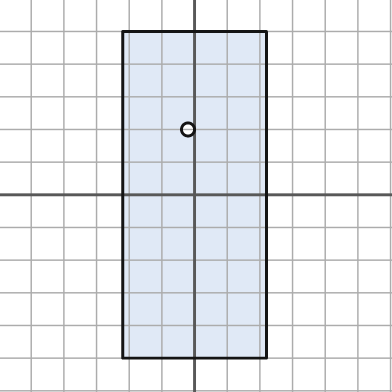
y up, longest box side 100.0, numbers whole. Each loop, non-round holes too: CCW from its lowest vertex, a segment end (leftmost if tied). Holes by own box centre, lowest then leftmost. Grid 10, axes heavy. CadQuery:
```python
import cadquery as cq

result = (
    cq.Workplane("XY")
    .moveTo(-22.0, -50.0)
    .lineTo(22.0, -50.0)
    .lineTo(22.0, 50.0)
    .lineTo(-22.0, 50.0)
    .close()
    .moveTo(-2.0, 20.0)
    .circle(2.0)
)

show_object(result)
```